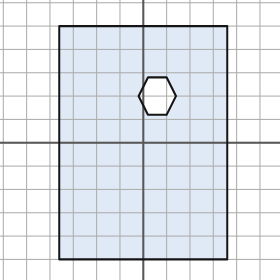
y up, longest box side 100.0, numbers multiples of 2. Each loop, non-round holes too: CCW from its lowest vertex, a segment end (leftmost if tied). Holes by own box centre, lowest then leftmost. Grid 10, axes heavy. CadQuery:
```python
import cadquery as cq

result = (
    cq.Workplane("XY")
    .moveTo(-36.0, -50.0)
    .lineTo(36.0, -50.0)
    .lineTo(36.0, 50.0)
    .lineTo(-36.0, 50.0)
    .close()
    .moveTo(2.0, 12.0)
    .lineTo(10.0, 12.0)
    .lineTo(14.0, 20.0)
    .lineTo(10.0, 28.0)
    .lineTo(2.0, 28.0)
    .lineTo(-2.0, 20.0)
    .close()
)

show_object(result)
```